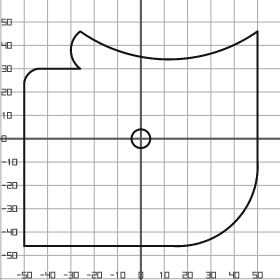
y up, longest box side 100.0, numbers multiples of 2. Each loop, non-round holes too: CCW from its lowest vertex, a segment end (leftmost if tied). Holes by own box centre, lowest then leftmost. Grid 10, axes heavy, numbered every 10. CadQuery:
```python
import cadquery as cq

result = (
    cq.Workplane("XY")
    .moveTo(-50.0, -46.0)
    .lineTo(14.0, -46.0)
    .threePointArc((40.0, -36.0), (50.0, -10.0))
    .lineTo(50.0, 46.0)
    .threePointArc((12.0, 34.0), (-26.0, 46.0))
    .threePointArc((-30.0, 38.0), (-26.0, 30.0))
    .lineTo(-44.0, 30.0)
    .threePointArc((-48.0, 28.0), (-50.0, 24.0))
    .close()
    .moveTo(0.0, 0.0)
    .circle(4.0)
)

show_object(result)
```